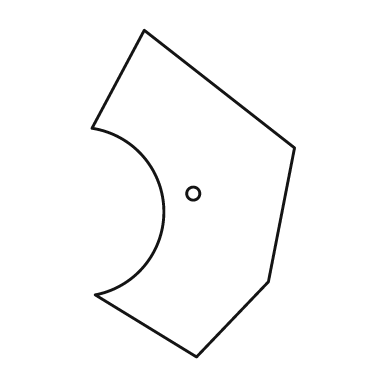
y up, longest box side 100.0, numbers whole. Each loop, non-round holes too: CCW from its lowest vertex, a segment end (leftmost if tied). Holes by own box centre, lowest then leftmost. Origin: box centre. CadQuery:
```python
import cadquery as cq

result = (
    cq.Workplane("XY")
    .moveTo(1.0, -50.0)
    .lineTo(23.0, -27.0)
    .lineTo(31.0, 14.0)
    .lineTo(-15.0, 50.0)
    .lineTo(-31.0, 20.0)
    .threePointArc((-9.0, -5.0), (-30.0, -31.0))
    .close()
    .moveTo(0.0, 0.0)
    .circle(2.0)
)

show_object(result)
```